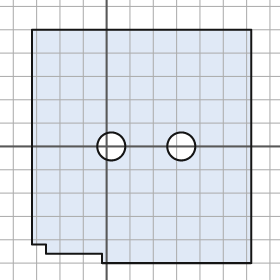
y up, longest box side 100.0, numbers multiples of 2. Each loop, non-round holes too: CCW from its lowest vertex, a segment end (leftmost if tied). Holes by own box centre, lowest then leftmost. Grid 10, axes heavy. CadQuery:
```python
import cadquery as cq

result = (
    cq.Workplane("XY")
    .moveTo(-2.0, -50.0)
    .lineTo(62.0, -50.0)
    .lineTo(62.0, 50.0)
    .lineTo(-32.0, 50.0)
    .lineTo(-32.0, -42.0)
    .lineTo(-26.0, -42.0)
    .lineTo(-26.0, -46.0)
    .lineTo(-2.0, -46.0)
    .close()
    .moveTo(2.0, 0.0)
    .circle(6.0)
    .moveTo(32.0, 0.0)
    .circle(6.0)
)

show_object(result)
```